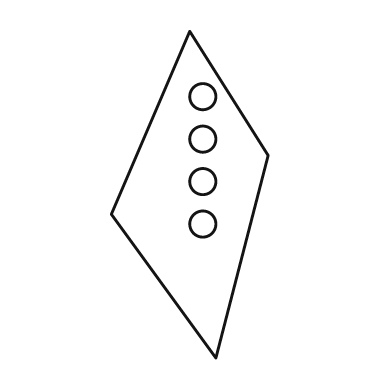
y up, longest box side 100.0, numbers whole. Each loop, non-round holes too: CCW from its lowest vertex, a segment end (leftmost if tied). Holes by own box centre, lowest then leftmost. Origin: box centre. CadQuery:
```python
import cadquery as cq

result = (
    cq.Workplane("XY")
    .moveTo(8.0, -50.0)
    .lineTo(24.0, 12.0)
    .lineTo(0.0, 50.0)
    .lineTo(-24.0, -6.0)
    .close()
    .moveTo(4.0, -9.0)
    .circle(4.0)
    .moveTo(4.0, 4.0)
    .circle(4.0)
    .moveTo(4.0, 17.0)
    .circle(4.0)
    .moveTo(4.0, 30.0)
    .circle(4.0)
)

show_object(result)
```